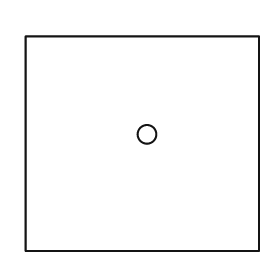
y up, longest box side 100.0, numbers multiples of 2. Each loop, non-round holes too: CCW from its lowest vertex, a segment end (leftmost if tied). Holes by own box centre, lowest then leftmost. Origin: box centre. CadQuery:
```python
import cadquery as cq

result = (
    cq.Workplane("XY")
    .moveTo(-50.0, -46.0)
    .lineTo(50.0, -46.0)
    .lineTo(50.0, 46.0)
    .lineTo(-50.0, 46.0)
    .close()
    .moveTo(2.0, 4.0)
    .circle(4.0)
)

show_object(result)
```